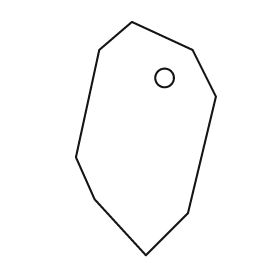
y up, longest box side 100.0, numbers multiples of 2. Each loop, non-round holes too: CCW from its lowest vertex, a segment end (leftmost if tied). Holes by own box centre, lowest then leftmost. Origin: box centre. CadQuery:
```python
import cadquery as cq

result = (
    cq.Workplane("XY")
    .moveTo(0.0, -50.0)
    .lineTo(18.0, -32.0)
    .lineTo(30.0, 18.0)
    .lineTo(20.0, 38.0)
    .lineTo(-6.0, 50.0)
    .lineTo(-20.0, 38.0)
    .lineTo(-30.0, -8.0)
    .lineTo(-22.0, -26.0)
    .close()
    .moveTo(8.0, 26.0)
    .circle(4.0)
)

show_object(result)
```